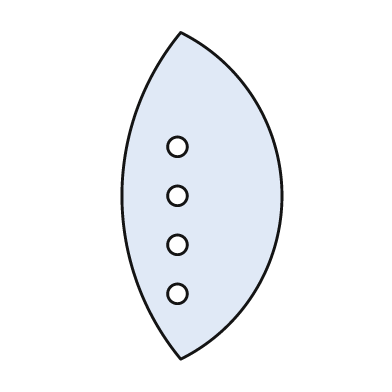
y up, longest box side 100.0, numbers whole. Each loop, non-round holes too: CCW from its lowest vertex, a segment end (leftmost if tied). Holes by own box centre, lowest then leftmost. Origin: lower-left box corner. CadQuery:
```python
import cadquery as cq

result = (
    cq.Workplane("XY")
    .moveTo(18.0, 0.0)
    .threePointArc((49.0, 50.0), (18.0, 100.0))
    .threePointArc((0.0, 50.0), (18.0, 0.0))
    .close()
    .moveTo(17.0, 20.0)
    .circle(3.0)
    .moveTo(17.0, 35.0)
    .circle(3.0)
    .moveTo(17.0, 50.0)
    .circle(3.0)
    .moveTo(17.0, 65.0)
    .circle(3.0)
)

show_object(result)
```